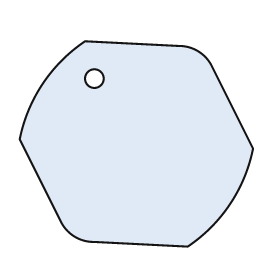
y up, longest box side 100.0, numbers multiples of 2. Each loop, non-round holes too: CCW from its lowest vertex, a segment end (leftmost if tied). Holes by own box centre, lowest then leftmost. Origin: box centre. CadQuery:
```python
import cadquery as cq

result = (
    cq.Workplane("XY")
    .moveTo(22.0, -44.0)
    .threePointArc((40.0, -26.0), (50.0, -2.0))
    .lineTo(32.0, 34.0)
    .threePointArc((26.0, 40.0), (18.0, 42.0))
    .lineTo(-22.0, 44.0)
    .threePointArc((-40.0, 26.0), (-50.0, 2.0))
    .lineTo(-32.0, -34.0)
    .threePointArc((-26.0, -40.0), (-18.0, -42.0))
    .close()
    .moveTo(-18.0, 28.0)
    .circle(4.0)
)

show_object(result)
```